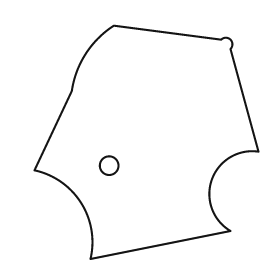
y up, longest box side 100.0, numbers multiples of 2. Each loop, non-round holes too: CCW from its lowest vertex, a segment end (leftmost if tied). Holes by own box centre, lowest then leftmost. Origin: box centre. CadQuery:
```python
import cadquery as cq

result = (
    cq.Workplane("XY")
    .moveTo(-24.0, -50.0)
    .lineTo(36.0, -38.0)
    .threePointArc((28.0, -16.0), (48.0, -4.0))
    .lineTo(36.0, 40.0)
    .threePointArc((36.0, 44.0), (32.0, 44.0))
    .lineTo(-14.0, 50.0)
    .threePointArc((-26.0, 38.0), (-32.0, 22.0))
    .lineTo(-48.0, -12.0)
    .threePointArc((-28.0, -26.0), (-24.0, -50.0))
    .close()
    .moveTo(-16.0, -10.0)
    .circle(4.0)
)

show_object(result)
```